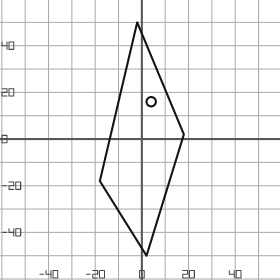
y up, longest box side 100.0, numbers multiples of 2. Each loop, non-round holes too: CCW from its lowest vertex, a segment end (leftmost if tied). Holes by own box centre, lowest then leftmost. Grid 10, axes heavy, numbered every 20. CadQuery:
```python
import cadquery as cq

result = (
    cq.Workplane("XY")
    .moveTo(2.0, -50.0)
    .lineTo(18.0, 2.0)
    .lineTo(-2.0, 50.0)
    .lineTo(-18.0, -18.0)
    .close()
    .moveTo(4.0, 16.0)
    .circle(2.0)
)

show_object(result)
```